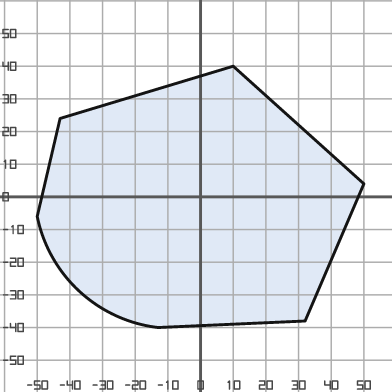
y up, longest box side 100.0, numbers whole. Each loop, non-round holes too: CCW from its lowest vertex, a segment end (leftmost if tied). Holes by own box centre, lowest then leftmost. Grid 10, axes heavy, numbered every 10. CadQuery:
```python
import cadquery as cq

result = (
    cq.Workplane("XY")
    .moveTo(-13.0, -40.0)
    .lineTo(32.0, -38.0)
    .lineTo(50.0, 4.0)
    .lineTo(10.0, 40.0)
    .lineTo(-43.0, 24.0)
    .lineTo(-50.0, -6.0)
    .threePointArc((-37.0, -29.0), (-13.0, -40.0))
    .close()
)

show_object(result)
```